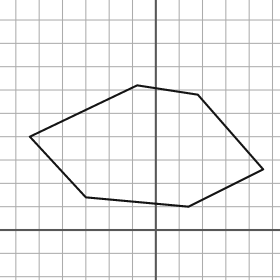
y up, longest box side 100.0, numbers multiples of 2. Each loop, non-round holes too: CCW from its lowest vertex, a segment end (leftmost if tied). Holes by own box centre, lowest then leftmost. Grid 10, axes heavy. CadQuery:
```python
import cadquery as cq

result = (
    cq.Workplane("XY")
    .moveTo(14.0, 10.0)
    .lineTo(46.0, 26.0)
    .lineTo(18.0, 58.0)
    .lineTo(-8.0, 62.0)
    .lineTo(-54.0, 40.0)
    .lineTo(-30.0, 14.0)
    .close()
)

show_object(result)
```